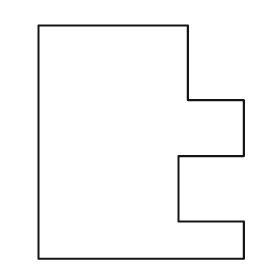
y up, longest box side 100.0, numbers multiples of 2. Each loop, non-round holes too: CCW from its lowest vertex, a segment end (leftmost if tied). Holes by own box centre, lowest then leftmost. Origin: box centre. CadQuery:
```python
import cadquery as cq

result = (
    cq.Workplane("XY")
    .moveTo(-44.0, -50.0)
    .lineTo(44.0, -50.0)
    .lineTo(44.0, -34.0)
    .lineTo(16.0, -34.0)
    .lineTo(16.0, -6.0)
    .lineTo(44.0, -6.0)
    .lineTo(44.0, 18.0)
    .lineTo(20.0, 18.0)
    .lineTo(20.0, 50.0)
    .lineTo(-44.0, 50.0)
    .close()
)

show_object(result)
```